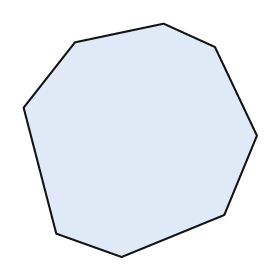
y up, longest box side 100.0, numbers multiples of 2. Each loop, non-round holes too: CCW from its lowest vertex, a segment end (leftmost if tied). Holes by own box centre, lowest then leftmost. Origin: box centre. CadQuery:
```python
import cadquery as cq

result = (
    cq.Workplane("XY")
    .moveTo(-8.0, -50.0)
    .lineTo(36.0, -32.0)
    .lineTo(50.0, 2.0)
    .lineTo(32.0, 40.0)
    .lineTo(10.0, 50.0)
    .lineTo(-28.0, 42.0)
    .lineTo(-50.0, 14.0)
    .lineTo(-36.0, -40.0)
    .close()
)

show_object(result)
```